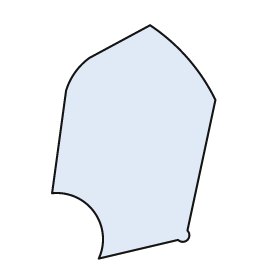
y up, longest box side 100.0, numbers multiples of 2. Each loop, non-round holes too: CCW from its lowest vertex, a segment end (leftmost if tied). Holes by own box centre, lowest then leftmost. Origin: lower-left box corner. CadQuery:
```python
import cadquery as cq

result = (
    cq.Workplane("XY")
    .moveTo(20.0, 0.0)
    .lineTo(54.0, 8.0)
    .threePointArc((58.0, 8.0), (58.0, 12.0))
    .lineTo(70.0, 68.0)
    .threePointArc((58.0, 86.0), (42.0, 100.0))
    .lineTo(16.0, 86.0)
    .threePointArc((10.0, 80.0), (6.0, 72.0))
    .lineTo(0.0, 28.0)
    .threePointArc((18.0, 20.0), (20.0, 0.0))
    .close()
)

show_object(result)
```